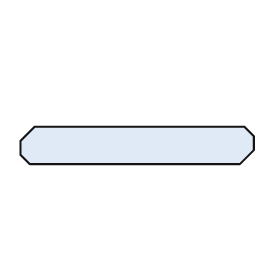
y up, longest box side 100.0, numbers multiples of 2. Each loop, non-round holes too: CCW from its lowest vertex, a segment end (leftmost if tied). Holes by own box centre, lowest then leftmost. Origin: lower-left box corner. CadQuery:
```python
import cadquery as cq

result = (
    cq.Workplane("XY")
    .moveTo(4.0, 0.0)
    .lineTo(94.0, 0.0)
    .lineTo(100.0, 6.0)
    .lineTo(100.0, 12.0)
    .lineTo(96.0, 16.0)
    .lineTo(6.0, 16.0)
    .lineTo(0.0, 10.0)
    .lineTo(0.0, 4.0)
    .close()
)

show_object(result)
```